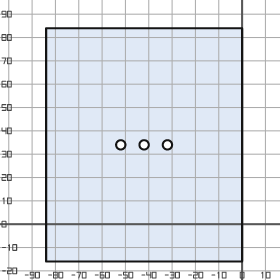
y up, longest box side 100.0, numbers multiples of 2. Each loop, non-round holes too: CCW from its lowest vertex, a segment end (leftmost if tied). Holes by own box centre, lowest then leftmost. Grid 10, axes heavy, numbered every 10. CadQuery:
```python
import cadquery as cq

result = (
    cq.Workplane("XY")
    .moveTo(-84.0, -16.0)
    .lineTo(0.0, -16.0)
    .lineTo(0.0, 84.0)
    .lineTo(-84.0, 84.0)
    .close()
    .moveTo(-52.0, 34.0)
    .circle(2.0)
    .moveTo(-42.0, 34.0)
    .circle(2.0)
    .moveTo(-32.0, 34.0)
    .circle(2.0)
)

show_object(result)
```